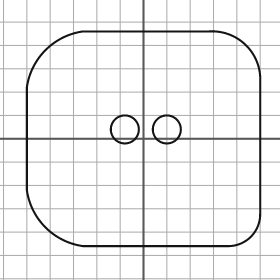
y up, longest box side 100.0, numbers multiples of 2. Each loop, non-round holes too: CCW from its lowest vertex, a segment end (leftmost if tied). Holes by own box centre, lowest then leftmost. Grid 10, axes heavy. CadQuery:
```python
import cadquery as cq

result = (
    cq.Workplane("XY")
    .moveTo(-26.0, -46.0)
    .lineTo(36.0, -46.0)
    .threePointArc((46.0, -42.0), (50.0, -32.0))
    .lineTo(50.0, 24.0)
    .threePointArc((44.0, 40.0), (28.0, 46.0))
    .lineTo(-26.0, 46.0)
    .threePointArc((-42.0, 38.0), (-50.0, 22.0))
    .lineTo(-50.0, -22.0)
    .threePointArc((-42.0, -38.0), (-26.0, -46.0))
    .close()
    .moveTo(-8.0, 4.0)
    .circle(6.0)
    .moveTo(10.0, 4.0)
    .circle(6.0)
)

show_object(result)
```